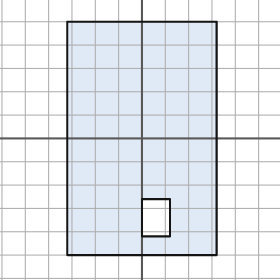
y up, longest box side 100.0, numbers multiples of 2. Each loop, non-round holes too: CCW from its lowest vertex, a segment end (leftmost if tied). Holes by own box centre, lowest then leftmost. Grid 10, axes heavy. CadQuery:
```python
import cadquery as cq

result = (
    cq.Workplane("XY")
    .moveTo(-32.0, -50.0)
    .lineTo(32.0, -50.0)
    .lineTo(32.0, 50.0)
    .lineTo(-32.0, 50.0)
    .close()
    .moveTo(0.0, -42.0)
    .lineTo(12.0, -42.0)
    .lineTo(12.0, -26.0)
    .lineTo(0.0, -26.0)
    .close()
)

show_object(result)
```